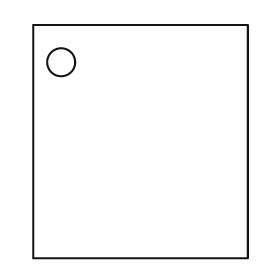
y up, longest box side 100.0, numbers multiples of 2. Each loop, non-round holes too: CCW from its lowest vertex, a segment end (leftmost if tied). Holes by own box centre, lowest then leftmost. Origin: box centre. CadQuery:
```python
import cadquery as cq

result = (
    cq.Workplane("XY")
    .moveTo(-46.0, -50.0)
    .lineTo(46.0, -50.0)
    .lineTo(46.0, 50.0)
    .lineTo(-46.0, 50.0)
    .close()
    .moveTo(-34.0, 34.0)
    .circle(6.0)
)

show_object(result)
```